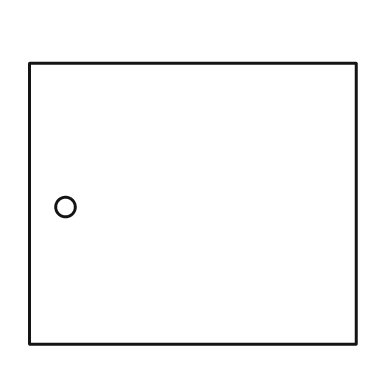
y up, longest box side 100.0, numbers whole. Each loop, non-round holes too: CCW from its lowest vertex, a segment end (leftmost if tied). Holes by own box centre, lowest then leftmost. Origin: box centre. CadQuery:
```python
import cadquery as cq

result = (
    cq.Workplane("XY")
    .moveTo(-50.0, -43.0)
    .lineTo(50.0, -43.0)
    .lineTo(50.0, 43.0)
    .lineTo(-50.0, 43.0)
    .close()
    .moveTo(-39.0, -1.0)
    .circle(3.0)
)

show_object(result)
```